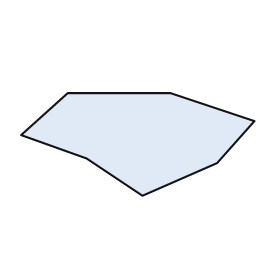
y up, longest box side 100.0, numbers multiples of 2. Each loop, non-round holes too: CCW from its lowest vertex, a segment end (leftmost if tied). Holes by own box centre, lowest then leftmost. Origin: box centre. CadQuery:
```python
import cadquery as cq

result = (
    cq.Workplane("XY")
    .moveTo(2.0, -22.0)
    .lineTo(34.0, -8.0)
    .lineTo(50.0, 10.0)
    .lineTo(14.0, 22.0)
    .lineTo(-30.0, 22.0)
    .lineTo(-50.0, 4.0)
    .lineTo(-22.0, -6.0)
    .close()
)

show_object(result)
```